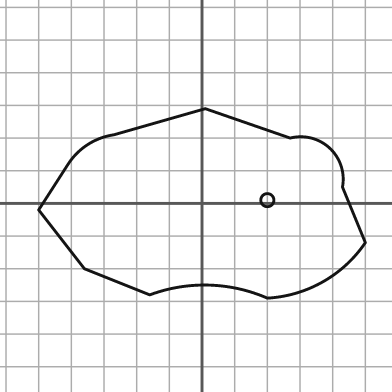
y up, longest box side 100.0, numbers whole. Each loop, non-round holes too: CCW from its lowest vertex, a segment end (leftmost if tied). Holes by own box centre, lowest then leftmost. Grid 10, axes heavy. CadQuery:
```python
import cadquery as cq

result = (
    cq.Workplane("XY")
    .moveTo(20.0, -29.0)
    .threePointArc((37.0, -24.0), (50.0, -12.0))
    .lineTo(43.0, 5.0)
    .threePointArc((39.0, 17.0), (27.0, 20.0))
    .lineTo(1.0, 29.0)
    .lineTo(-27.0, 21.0)
    .threePointArc((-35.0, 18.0), (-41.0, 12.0))
    .lineTo(-50.0, -2.0)
    .lineTo(-36.0, -20.0)
    .lineTo(-16.0, -28.0)
    .threePointArc((2.0, -25.0), (20.0, -29.0))
    .close()
    .moveTo(20.0, 1.0)
    .circle(2.0)
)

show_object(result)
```